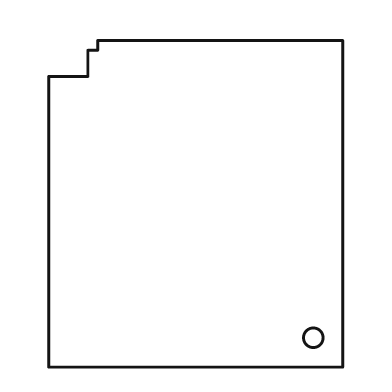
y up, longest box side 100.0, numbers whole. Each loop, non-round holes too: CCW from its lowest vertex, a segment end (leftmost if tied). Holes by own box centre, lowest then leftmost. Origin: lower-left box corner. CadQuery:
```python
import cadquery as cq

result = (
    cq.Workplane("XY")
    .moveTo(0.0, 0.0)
    .lineTo(90.0, 0.0)
    .lineTo(90.0, 100.0)
    .lineTo(15.0, 100.0)
    .lineTo(15.0, 97.0)
    .lineTo(12.0, 97.0)
    .lineTo(12.0, 89.0)
    .lineTo(0.0, 89.0)
    .close()
    .moveTo(81.0, 9.0)
    .circle(3.0)
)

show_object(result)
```